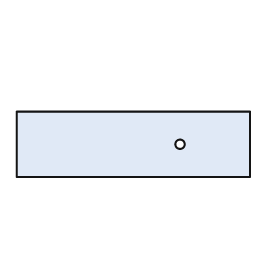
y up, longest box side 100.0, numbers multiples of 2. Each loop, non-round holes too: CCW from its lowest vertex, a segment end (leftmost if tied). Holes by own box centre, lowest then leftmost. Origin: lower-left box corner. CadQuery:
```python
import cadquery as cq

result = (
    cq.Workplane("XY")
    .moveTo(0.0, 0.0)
    .lineTo(100.0, 0.0)
    .lineTo(100.0, 28.0)
    .lineTo(0.0, 28.0)
    .close()
    .moveTo(70.0, 14.0)
    .circle(2.0)
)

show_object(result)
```